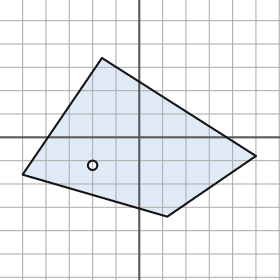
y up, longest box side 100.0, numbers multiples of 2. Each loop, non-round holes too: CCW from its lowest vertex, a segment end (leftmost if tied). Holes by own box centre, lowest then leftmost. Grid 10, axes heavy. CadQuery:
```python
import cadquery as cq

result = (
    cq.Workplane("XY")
    .moveTo(12.0, -34.0)
    .lineTo(50.0, -8.0)
    .lineTo(-16.0, 34.0)
    .lineTo(-50.0, -16.0)
    .close()
    .moveTo(-20.0, -12.0)
    .circle(2.0)
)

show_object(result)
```